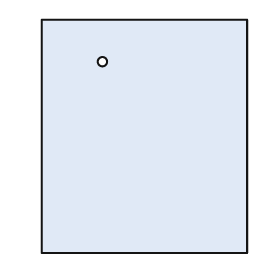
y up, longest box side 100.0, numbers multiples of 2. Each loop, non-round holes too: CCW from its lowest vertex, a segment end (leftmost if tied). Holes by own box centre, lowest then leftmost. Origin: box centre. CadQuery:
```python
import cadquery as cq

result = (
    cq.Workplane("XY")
    .moveTo(-44.0, -50.0)
    .lineTo(44.0, -50.0)
    .lineTo(44.0, 50.0)
    .lineTo(-44.0, 50.0)
    .close()
    .moveTo(-18.0, 32.0)
    .circle(2.0)
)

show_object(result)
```